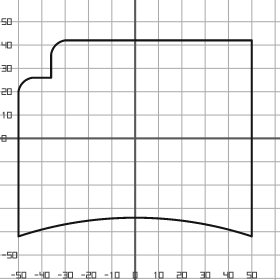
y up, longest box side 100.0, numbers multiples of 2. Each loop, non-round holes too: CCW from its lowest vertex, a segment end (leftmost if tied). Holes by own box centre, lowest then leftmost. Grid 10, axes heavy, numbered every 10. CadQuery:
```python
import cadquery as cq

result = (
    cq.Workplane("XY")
    .moveTo(-50.0, -42.0)
    .threePointArc((0.0, -34.0), (50.0, -42.0))
    .lineTo(50.0, 42.0)
    .lineTo(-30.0, 42.0)
    .threePointArc((-34.0, 40.0), (-36.0, 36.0))
    .lineTo(-36.0, 26.0)
    .lineTo(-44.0, 26.0)
    .threePointArc((-48.0, 24.0), (-50.0, 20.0))
    .close()
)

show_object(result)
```